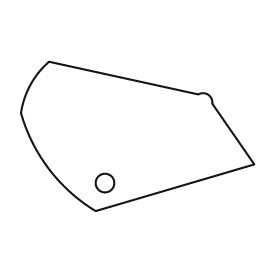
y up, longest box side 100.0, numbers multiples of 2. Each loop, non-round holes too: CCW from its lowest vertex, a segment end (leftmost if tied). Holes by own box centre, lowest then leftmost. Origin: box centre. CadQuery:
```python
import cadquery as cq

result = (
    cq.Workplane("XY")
    .moveTo(-18.0, -32.0)
    .lineTo(50.0, -12.0)
    .lineTo(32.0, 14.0)
    .threePointArc((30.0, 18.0), (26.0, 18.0))
    .lineTo(-38.0, 32.0)
    .threePointArc((-46.0, 22.0), (-50.0, 10.0))
    .threePointArc((-38.0, -14.0), (-18.0, -32.0))
    .close()
    .moveTo(-14.0, -20.0)
    .circle(4.0)
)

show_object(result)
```